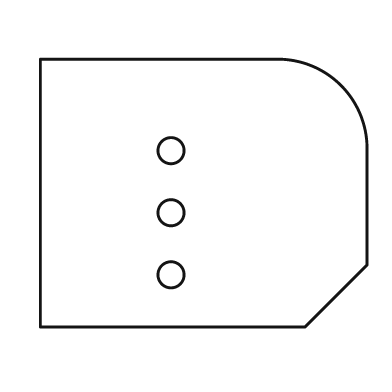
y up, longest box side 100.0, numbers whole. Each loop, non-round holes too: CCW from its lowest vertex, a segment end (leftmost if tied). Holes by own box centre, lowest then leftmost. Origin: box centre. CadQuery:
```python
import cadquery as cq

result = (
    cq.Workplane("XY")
    .moveTo(-50.0, -41.0)
    .lineTo(31.0, -41.0)
    .lineTo(50.0, -22.0)
    .lineTo(50.0, 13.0)
    .threePointArc((42.0, 33.0), (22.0, 41.0))
    .lineTo(-50.0, 41.0)
    .close()
    .moveTo(-10.0, -25.0)
    .circle(4.0)
    .moveTo(-10.0, -6.0)
    .circle(4.0)
    .moveTo(-10.0, 13.0)
    .circle(4.0)
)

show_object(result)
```